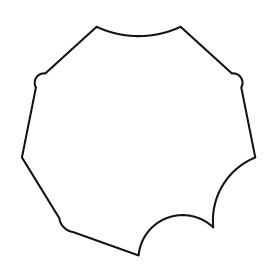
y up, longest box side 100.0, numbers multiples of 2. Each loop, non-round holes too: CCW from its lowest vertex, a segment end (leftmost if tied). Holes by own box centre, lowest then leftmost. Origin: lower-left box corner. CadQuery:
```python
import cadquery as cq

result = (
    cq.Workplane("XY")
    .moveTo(50.0, 0.0)
    .threePointArc((62.0, 16.0), (82.0, 12.0))
    .threePointArc((86.0, 30.0), (100.0, 42.0))
    .lineTo(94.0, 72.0)
    .threePointArc((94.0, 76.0), (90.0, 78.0))
    .lineTo(68.0, 98.0)
    .threePointArc((50.0, 94.0), (32.0, 98.0))
    .lineTo(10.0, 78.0)
    .threePointArc((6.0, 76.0), (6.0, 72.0))
    .lineTo(0.0, 42.0)
    .lineTo(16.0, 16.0)
    .threePointArc((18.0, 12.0), (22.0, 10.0))
    .close()
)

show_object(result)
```